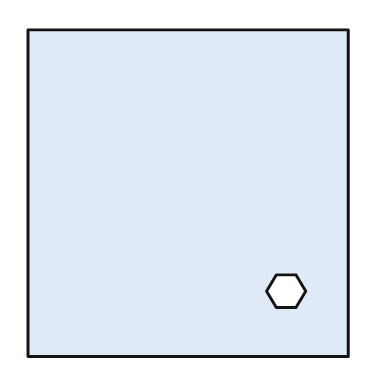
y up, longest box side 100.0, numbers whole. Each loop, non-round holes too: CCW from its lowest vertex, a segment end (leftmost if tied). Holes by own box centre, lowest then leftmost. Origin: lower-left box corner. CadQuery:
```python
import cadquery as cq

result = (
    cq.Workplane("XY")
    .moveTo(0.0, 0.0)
    .lineTo(98.0, 0.0)
    .lineTo(98.0, 100.0)
    .lineTo(0.0, 100.0)
    .close()
    .moveTo(76.0, 15.0)
    .lineTo(82.0, 15.0)
    .lineTo(85.0, 20.0)
    .lineTo(82.0, 25.0)
    .lineTo(76.0, 25.0)
    .lineTo(73.0, 20.0)
    .close()
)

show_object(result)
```